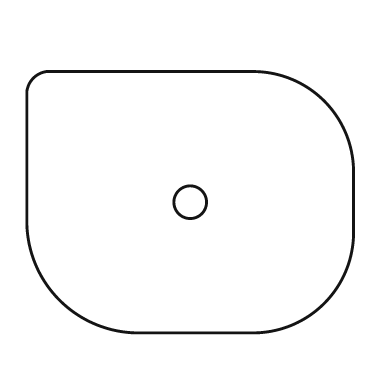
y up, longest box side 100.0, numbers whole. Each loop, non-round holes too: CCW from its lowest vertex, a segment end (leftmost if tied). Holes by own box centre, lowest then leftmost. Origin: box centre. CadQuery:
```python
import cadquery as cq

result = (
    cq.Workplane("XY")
    .moveTo(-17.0, -40.0)
    .lineTo(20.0, -40.0)
    .threePointArc((41.0, -31.0), (50.0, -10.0))
    .lineTo(50.0, 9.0)
    .threePointArc((41.0, 31.0), (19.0, 40.0))
    .lineTo(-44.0, 40.0)
    .threePointArc((-48.0, 38.0), (-50.0, 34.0))
    .lineTo(-50.0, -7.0)
    .threePointArc((-40.0, -30.0), (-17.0, -40.0))
    .close()
    .moveTo(0.0, 0.0)
    .circle(5.0)
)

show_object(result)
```